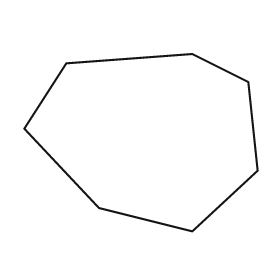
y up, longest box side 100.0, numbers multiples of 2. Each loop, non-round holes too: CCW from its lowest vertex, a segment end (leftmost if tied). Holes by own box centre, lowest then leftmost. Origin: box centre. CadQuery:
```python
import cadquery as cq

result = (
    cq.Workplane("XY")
    .moveTo(22.0, -38.0)
    .lineTo(50.0, -12.0)
    .lineTo(46.0, 26.0)
    .lineTo(22.0, 38.0)
    .lineTo(-32.0, 34.0)
    .lineTo(-50.0, 6.0)
    .lineTo(-18.0, -28.0)
    .close()
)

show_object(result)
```